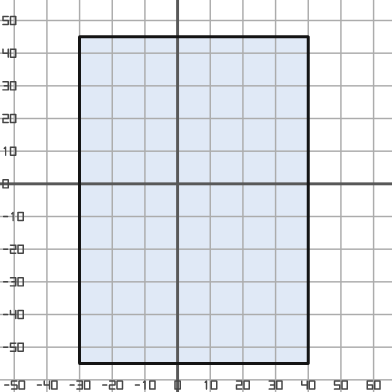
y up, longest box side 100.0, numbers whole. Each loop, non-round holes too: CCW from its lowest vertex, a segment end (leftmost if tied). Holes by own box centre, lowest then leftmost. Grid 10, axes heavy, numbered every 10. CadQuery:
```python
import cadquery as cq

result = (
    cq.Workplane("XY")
    .moveTo(-30.0, -55.0)
    .lineTo(40.0, -55.0)
    .lineTo(40.0, 45.0)
    .lineTo(-30.0, 45.0)
    .close()
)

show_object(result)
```